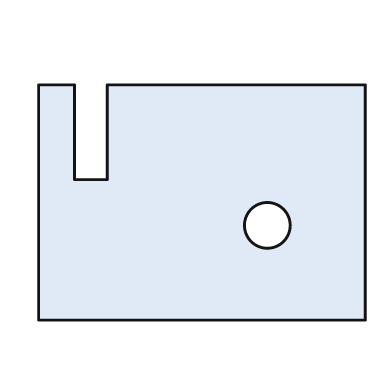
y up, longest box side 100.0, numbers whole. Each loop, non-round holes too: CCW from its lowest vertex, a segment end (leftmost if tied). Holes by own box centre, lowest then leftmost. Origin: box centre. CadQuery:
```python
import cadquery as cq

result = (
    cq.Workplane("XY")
    .moveTo(-50.0, -36.0)
    .lineTo(50.0, -36.0)
    .lineTo(50.0, 36.0)
    .lineTo(-29.0, 36.0)
    .lineTo(-29.0, 7.0)
    .lineTo(-39.0, 7.0)
    .lineTo(-39.0, 36.0)
    .lineTo(-50.0, 36.0)
    .close()
    .moveTo(20.0, -7.0)
    .circle(7.0)
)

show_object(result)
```